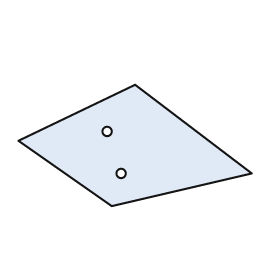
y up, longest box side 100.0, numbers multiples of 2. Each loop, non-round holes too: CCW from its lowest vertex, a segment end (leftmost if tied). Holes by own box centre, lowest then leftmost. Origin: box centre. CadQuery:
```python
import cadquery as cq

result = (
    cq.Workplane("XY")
    .moveTo(-10.0, -26.0)
    .lineTo(50.0, -12.0)
    .lineTo(0.0, 26.0)
    .lineTo(-50.0, 2.0)
    .close()
    .moveTo(-6.0, -12.0)
    .circle(2.0)
    .moveTo(-12.0, 6.0)
    .circle(2.0)
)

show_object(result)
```